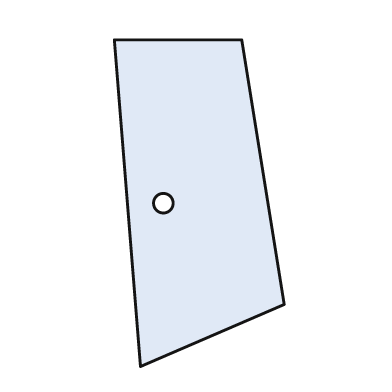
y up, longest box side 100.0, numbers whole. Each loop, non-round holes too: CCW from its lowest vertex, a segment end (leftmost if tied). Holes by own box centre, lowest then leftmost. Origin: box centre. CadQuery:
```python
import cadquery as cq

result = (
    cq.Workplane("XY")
    .moveTo(-18.0, -50.0)
    .lineTo(26.0, -31.0)
    .lineTo(13.0, 50.0)
    .lineTo(-26.0, 50.0)
    .close()
    .moveTo(-11.0, 0.0)
    .circle(3.0)
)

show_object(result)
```